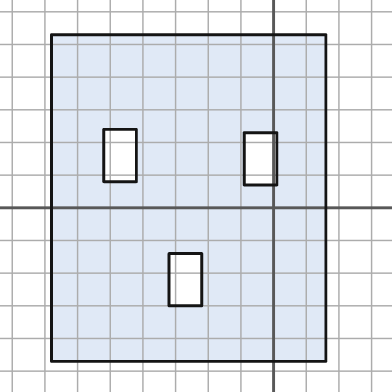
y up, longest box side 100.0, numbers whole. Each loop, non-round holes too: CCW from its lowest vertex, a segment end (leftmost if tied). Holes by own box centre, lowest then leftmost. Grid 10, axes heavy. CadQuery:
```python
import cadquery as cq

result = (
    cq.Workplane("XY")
    .moveTo(-68.0, -47.0)
    .lineTo(16.0, -47.0)
    .lineTo(16.0, 53.0)
    .lineTo(-68.0, 53.0)
    .close()
    .moveTo(-32.0, -30.0)
    .lineTo(-22.0, -30.0)
    .lineTo(-22.0, -14.0)
    .lineTo(-32.0, -14.0)
    .close()
    .moveTo(-9.0, 7.0)
    .lineTo(1.0, 7.0)
    .lineTo(1.0, 23.0)
    .lineTo(-9.0, 23.0)
    .close()
    .moveTo(-52.0, 8.0)
    .lineTo(-42.0, 8.0)
    .lineTo(-42.0, 24.0)
    .lineTo(-52.0, 24.0)
    .close()
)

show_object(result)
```